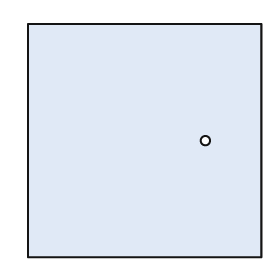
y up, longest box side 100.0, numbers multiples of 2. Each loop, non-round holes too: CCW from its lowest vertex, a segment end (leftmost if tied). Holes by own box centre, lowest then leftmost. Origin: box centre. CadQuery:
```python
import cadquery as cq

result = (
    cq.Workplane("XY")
    .moveTo(-50.0, -50.0)
    .lineTo(50.0, -50.0)
    .lineTo(50.0, 50.0)
    .lineTo(-50.0, 50.0)
    .close()
    .moveTo(26.0, 0.0)
    .circle(2.0)
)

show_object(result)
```